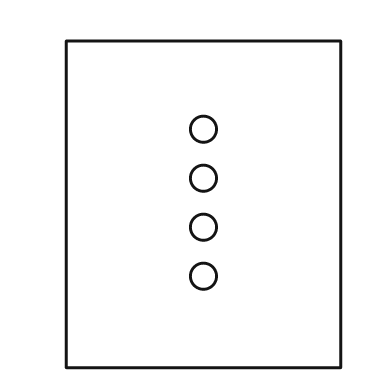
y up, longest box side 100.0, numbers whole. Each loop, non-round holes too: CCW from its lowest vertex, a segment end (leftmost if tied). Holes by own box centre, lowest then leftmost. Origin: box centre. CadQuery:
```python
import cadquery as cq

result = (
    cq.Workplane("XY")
    .moveTo(-42.0, -50.0)
    .lineTo(42.0, -50.0)
    .lineTo(42.0, 50.0)
    .lineTo(-42.0, 50.0)
    .close()
    .moveTo(0.0, -22.0)
    .circle(4.0)
    .moveTo(0.0, -7.0)
    .circle(4.0)
    .moveTo(0.0, 8.0)
    .circle(4.0)
    .moveTo(0.0, 23.0)
    .circle(4.0)
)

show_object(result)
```